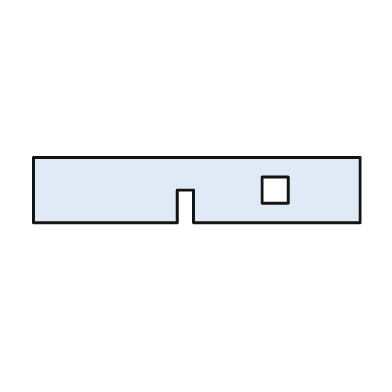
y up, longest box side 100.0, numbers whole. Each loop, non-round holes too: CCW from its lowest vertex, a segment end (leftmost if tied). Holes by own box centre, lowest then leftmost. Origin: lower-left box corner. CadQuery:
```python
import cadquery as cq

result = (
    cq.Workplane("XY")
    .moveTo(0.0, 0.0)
    .lineTo(44.0, 0.0)
    .lineTo(44.0, 10.0)
    .lineTo(49.0, 10.0)
    .lineTo(49.0, 0.0)
    .lineTo(100.0, 0.0)
    .lineTo(100.0, 20.0)
    .lineTo(0.0, 20.0)
    .close()
    .moveTo(70.0, 6.0)
    .lineTo(78.0, 6.0)
    .lineTo(78.0, 14.0)
    .lineTo(70.0, 14.0)
    .close()
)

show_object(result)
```